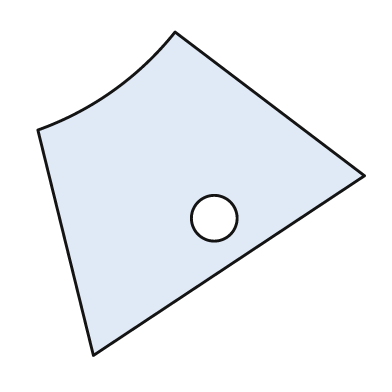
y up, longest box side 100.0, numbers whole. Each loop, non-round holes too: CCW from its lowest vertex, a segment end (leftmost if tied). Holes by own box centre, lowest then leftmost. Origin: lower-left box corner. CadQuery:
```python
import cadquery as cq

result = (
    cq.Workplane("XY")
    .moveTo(17.0, 0.0)
    .lineTo(100.0, 55.0)
    .lineTo(42.0, 99.0)
    .threePointArc((23.0, 81.0), (0.0, 69.0))
    .close()
    .moveTo(54.0, 42.0)
    .circle(7.0)
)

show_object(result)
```